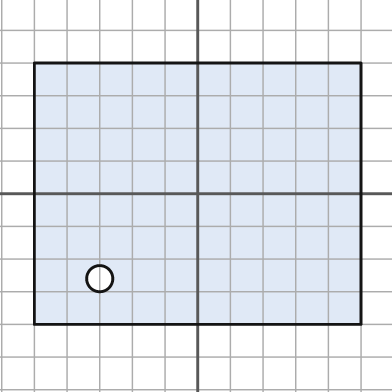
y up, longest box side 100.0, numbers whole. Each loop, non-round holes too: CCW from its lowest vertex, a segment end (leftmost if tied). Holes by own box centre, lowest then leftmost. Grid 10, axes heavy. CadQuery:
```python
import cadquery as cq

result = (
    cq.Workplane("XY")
    .moveTo(-50.0, -40.0)
    .lineTo(50.0, -40.0)
    .lineTo(50.0, 40.0)
    .lineTo(-50.0, 40.0)
    .close()
    .moveTo(-30.0, -26.0)
    .circle(4.0)
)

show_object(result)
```